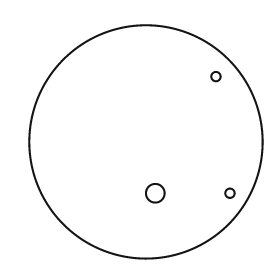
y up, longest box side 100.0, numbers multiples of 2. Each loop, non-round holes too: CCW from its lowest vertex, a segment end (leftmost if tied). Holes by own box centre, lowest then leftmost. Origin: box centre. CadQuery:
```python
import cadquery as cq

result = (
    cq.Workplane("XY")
    .moveTo(0.0, 0.0)
    .circle(50.0)
    .moveTo(4.0, -22.0)
    .circle(4.0)
    .moveTo(36.0, -22.0)
    .circle(2.0)
    .moveTo(30.0, 28.0)
    .circle(2.0)
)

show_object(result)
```